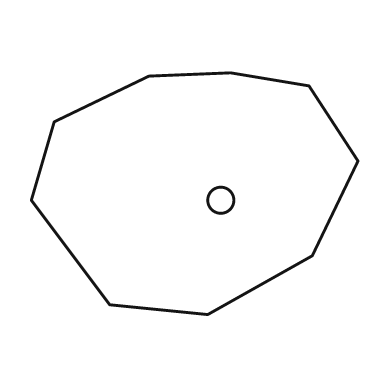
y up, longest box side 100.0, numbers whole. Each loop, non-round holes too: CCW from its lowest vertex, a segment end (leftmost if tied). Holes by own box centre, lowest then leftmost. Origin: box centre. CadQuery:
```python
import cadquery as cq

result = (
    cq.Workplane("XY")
    .moveTo(4.0, -37.0)
    .lineTo(36.0, -19.0)
    .lineTo(50.0, 10.0)
    .lineTo(35.0, 33.0)
    .lineTo(11.0, 37.0)
    .lineTo(-14.0, 36.0)
    .lineTo(-43.0, 22.0)
    .lineTo(-50.0, -2.0)
    .lineTo(-26.0, -34.0)
    .close()
    .moveTo(8.0, -2.0)
    .circle(4.0)
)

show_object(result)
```